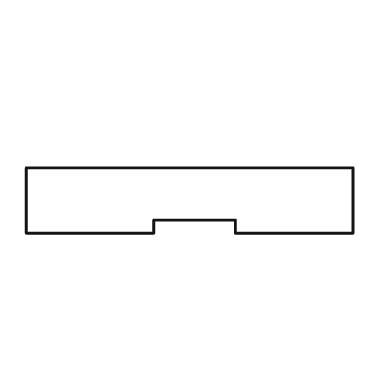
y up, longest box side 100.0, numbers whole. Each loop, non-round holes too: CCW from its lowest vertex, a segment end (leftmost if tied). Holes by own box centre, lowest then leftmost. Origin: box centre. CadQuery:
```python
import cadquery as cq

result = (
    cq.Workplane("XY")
    .moveTo(-50.0, -10.0)
    .lineTo(-11.0, -10.0)
    .lineTo(-11.0, -6.0)
    .lineTo(14.0, -6.0)
    .lineTo(14.0, -10.0)
    .lineTo(50.0, -10.0)
    .lineTo(50.0, 10.0)
    .lineTo(-50.0, 10.0)
    .close()
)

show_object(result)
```